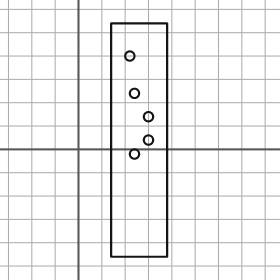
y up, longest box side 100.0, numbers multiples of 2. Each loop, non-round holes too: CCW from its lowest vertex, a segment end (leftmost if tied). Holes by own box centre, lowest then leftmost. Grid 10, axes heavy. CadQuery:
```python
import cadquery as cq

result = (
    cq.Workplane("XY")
    .moveTo(14.0, -46.0)
    .lineTo(38.0, -46.0)
    .lineTo(38.0, 54.0)
    .lineTo(14.0, 54.0)
    .close()
    .moveTo(24.0, -2.0)
    .circle(2.0)
    .moveTo(30.0, 4.0)
    .circle(2.0)
    .moveTo(30.0, 14.0)
    .circle(2.0)
    .moveTo(24.0, 24.0)
    .circle(2.0)
    .moveTo(22.0, 40.0)
    .circle(2.0)
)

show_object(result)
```